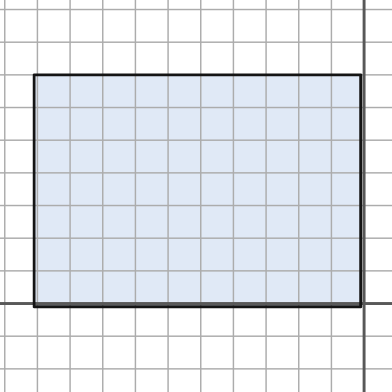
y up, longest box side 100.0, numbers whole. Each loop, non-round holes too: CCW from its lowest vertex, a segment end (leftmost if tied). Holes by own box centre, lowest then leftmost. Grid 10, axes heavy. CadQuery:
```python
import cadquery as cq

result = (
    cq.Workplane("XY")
    .moveTo(-101.0, -1.0)
    .lineTo(-1.0, -1.0)
    .lineTo(-1.0, 70.0)
    .lineTo(-101.0, 70.0)
    .close()
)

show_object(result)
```